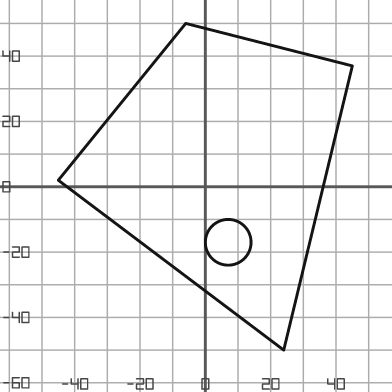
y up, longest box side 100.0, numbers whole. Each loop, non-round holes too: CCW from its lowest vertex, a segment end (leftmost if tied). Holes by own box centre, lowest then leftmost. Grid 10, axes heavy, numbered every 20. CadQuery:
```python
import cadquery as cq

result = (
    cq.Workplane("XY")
    .moveTo(24.0, -50.0)
    .lineTo(45.0, 37.0)
    .lineTo(-6.0, 50.0)
    .lineTo(-45.0, 2.0)
    .close()
    .moveTo(7.0, -17.0)
    .circle(7.0)
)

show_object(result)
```